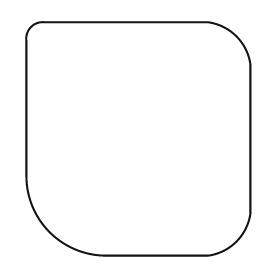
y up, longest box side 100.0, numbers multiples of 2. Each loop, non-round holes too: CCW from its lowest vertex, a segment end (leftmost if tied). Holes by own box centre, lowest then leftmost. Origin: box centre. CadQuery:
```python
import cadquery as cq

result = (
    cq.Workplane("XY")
    .moveTo(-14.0, -50.0)
    .lineTo(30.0, -50.0)
    .threePointArc((42.0, -44.0), (48.0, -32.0))
    .lineTo(48.0, 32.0)
    .threePointArc((42.0, 44.0), (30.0, 50.0))
    .lineTo(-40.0, 50.0)
    .threePointArc((-46.0, 48.0), (-48.0, 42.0))
    .lineTo(-48.0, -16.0)
    .threePointArc((-38.0, -40.0), (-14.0, -50.0))
    .close()
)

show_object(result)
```